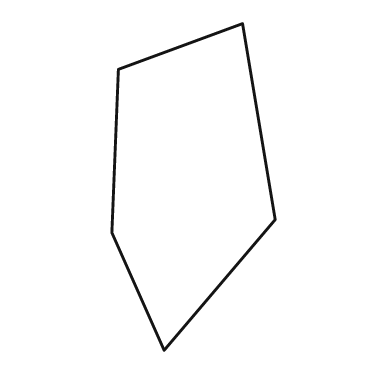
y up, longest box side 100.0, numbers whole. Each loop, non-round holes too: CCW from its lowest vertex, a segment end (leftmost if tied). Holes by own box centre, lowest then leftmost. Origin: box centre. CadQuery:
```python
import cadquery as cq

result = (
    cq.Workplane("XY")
    .moveTo(-9.0, -50.0)
    .lineTo(25.0, -10.0)
    .lineTo(15.0, 50.0)
    .lineTo(-23.0, 36.0)
    .lineTo(-25.0, -14.0)
    .close()
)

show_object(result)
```